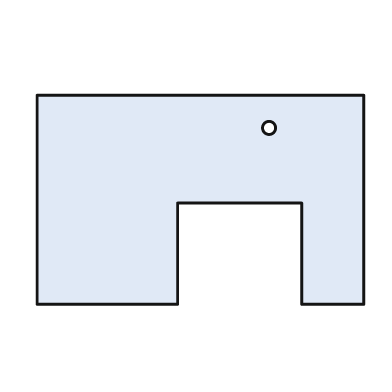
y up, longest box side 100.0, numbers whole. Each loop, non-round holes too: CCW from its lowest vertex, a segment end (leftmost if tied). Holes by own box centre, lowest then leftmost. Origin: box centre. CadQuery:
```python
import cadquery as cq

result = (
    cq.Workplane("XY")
    .moveTo(-50.0, -32.0)
    .lineTo(-7.0, -32.0)
    .lineTo(-7.0, -1.0)
    .lineTo(31.0, -1.0)
    .lineTo(31.0, -32.0)
    .lineTo(50.0, -32.0)
    .lineTo(50.0, 32.0)
    .lineTo(-50.0, 32.0)
    .close()
    .moveTo(21.0, 22.0)
    .circle(2.0)
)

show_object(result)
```